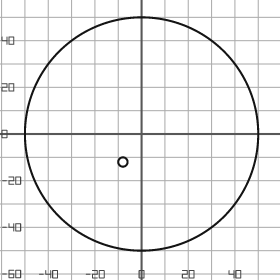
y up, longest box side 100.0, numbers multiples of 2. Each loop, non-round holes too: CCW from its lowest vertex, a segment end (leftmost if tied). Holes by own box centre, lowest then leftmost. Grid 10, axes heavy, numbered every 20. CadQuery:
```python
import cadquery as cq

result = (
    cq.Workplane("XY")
    .moveTo(0.0, 0.0)
    .circle(50.0)
    .moveTo(-8.0, -12.0)
    .circle(2.0)
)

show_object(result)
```